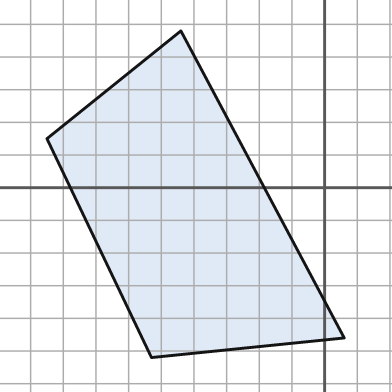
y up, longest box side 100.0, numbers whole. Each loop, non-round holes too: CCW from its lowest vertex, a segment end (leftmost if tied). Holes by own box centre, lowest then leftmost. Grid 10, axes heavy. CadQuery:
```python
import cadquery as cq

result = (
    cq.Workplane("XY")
    .moveTo(-53.0, -52.0)
    .lineTo(6.0, -46.0)
    .lineTo(-44.0, 48.0)
    .lineTo(-85.0, 15.0)
    .close()
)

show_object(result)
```